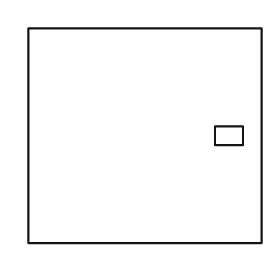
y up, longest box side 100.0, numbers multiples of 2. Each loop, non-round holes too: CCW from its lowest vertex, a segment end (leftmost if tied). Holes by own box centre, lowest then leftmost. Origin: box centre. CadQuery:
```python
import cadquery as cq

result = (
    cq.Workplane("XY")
    .moveTo(-50.0, -46.0)
    .lineTo(50.0, -46.0)
    .lineTo(50.0, 46.0)
    .lineTo(-50.0, 46.0)
    .close()
    .moveTo(30.0, -4.0)
    .lineTo(42.0, -4.0)
    .lineTo(42.0, 4.0)
    .lineTo(30.0, 4.0)
    .close()
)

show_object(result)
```